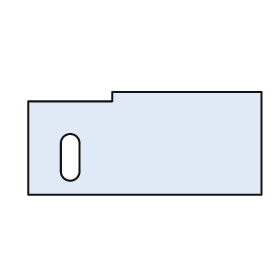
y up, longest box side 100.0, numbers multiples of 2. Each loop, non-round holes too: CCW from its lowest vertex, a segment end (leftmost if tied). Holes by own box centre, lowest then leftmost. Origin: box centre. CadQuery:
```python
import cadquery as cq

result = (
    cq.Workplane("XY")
    .moveTo(-50.0, -22.0)
    .lineTo(50.0, -22.0)
    .lineTo(50.0, 22.0)
    .lineTo(-14.0, 22.0)
    .lineTo(-14.0, 18.0)
    .lineTo(-50.0, 18.0)
    .close()
    .moveTo(-36.0, -12.0)
    .threePointArc((-32.0, -16.0), (-28.0, -12.0))
    .lineTo(-28.0, 0.0)
    .threePointArc((-32.0, 4.0), (-36.0, 0.0))
    .close()
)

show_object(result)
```